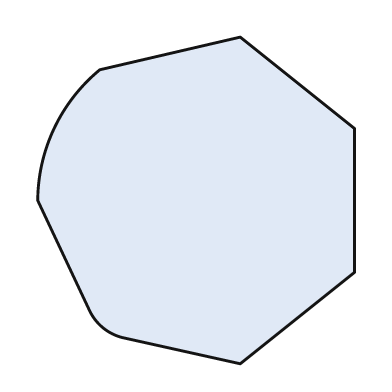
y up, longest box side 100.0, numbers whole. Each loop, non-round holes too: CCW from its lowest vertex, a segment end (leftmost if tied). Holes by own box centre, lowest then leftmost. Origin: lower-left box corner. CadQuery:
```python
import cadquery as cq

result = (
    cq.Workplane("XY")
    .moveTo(62.0, 0.0)
    .lineTo(97.0, 28.0)
    .lineTo(97.0, 72.0)
    .lineTo(62.0, 100.0)
    .lineTo(19.0, 90.0)
    .threePointArc((5.0, 72.0), (0.0, 50.0))
    .lineTo(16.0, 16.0)
    .threePointArc((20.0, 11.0), (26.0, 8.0))
    .close()
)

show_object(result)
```